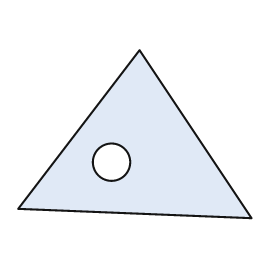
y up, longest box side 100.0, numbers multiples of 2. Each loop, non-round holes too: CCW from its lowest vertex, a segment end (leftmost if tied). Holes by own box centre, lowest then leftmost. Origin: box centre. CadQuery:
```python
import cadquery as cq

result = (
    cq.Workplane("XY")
    .moveTo(50.0, -36.0)
    .lineTo(2.0, 36.0)
    .lineTo(-50.0, -32.0)
    .close()
    .moveTo(-10.0, -12.0)
    .circle(8.0)
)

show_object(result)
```